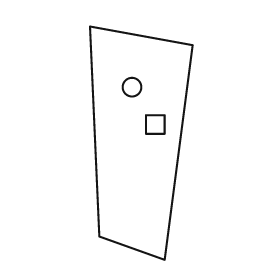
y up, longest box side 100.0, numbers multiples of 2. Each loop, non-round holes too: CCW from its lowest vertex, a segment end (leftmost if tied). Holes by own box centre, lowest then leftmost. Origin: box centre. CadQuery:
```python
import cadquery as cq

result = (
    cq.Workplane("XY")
    .moveTo(10.0, -50.0)
    .lineTo(22.0, 42.0)
    .lineTo(-22.0, 50.0)
    .lineTo(-18.0, -40.0)
    .close()
    .moveTo(2.0, 4.0)
    .lineTo(10.0, 4.0)
    .lineTo(10.0, 12.0)
    .lineTo(2.0, 12.0)
    .close()
    .moveTo(-4.0, 24.0)
    .circle(4.0)
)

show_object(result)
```